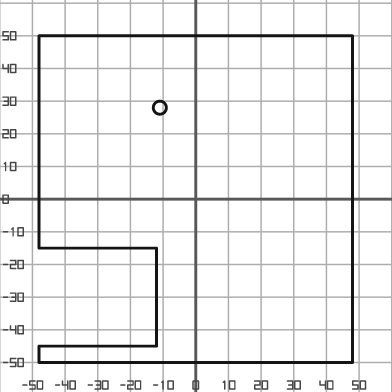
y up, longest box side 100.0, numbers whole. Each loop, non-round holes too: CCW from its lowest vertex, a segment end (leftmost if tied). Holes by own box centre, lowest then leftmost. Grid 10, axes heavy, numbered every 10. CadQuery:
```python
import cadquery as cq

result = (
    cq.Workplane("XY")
    .moveTo(-48.0, -50.0)
    .lineTo(48.0, -50.0)
    .lineTo(48.0, 50.0)
    .lineTo(-48.0, 50.0)
    .lineTo(-48.0, -15.0)
    .lineTo(-12.0, -15.0)
    .lineTo(-12.0, -45.0)
    .lineTo(-48.0, -45.0)
    .close()
    .moveTo(-11.0, 28.0)
    .circle(2.0)
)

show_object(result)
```